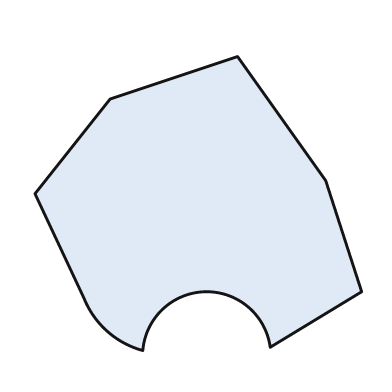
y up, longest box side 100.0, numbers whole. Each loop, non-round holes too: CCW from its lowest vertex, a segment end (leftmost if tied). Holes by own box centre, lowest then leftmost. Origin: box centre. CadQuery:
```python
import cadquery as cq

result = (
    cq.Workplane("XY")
    .moveTo(-17.0, -45.0)
    .threePointArc((2.0, -27.0), (22.0, -44.0))
    .lineTo(50.0, -27.0)
    .lineTo(39.0, 7.0)
    .lineTo(12.0, 45.0)
    .lineTo(-27.0, 32.0)
    .lineTo(-50.0, 3.0)
    .lineTo(-35.0, -29.0)
    .threePointArc((-28.0, -39.0), (-17.0, -45.0))
    .close()
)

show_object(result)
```